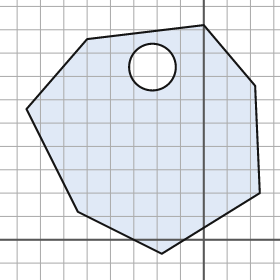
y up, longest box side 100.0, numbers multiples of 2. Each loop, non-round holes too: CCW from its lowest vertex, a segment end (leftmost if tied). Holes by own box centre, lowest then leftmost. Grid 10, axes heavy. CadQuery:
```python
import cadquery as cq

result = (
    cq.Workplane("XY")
    .moveTo(-18.0, -6.0)
    .lineTo(24.0, 20.0)
    .lineTo(22.0, 66.0)
    .lineTo(0.0, 92.0)
    .lineTo(-50.0, 86.0)
    .lineTo(-76.0, 56.0)
    .lineTo(-54.0, 12.0)
    .close()
    .moveTo(-22.0, 74.0)
    .circle(10.0)
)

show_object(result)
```